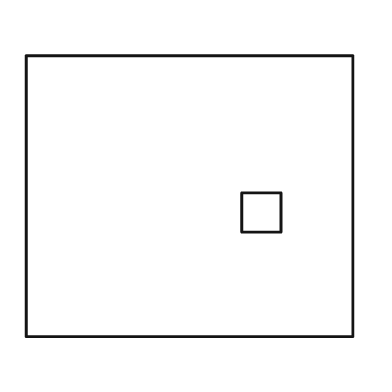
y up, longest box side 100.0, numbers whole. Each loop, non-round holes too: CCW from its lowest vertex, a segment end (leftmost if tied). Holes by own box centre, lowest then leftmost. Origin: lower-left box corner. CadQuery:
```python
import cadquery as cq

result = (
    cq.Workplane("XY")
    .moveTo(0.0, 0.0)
    .lineTo(100.0, 0.0)
    .lineTo(100.0, 86.0)
    .lineTo(0.0, 86.0)
    .close()
    .moveTo(66.0, 32.0)
    .lineTo(78.0, 32.0)
    .lineTo(78.0, 44.0)
    .lineTo(66.0, 44.0)
    .close()
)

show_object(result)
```